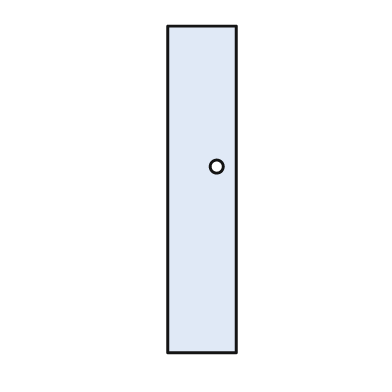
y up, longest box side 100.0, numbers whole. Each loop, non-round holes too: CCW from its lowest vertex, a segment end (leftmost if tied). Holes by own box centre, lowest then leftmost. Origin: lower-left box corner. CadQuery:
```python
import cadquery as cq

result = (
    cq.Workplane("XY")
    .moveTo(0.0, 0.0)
    .lineTo(21.0, 0.0)
    .lineTo(21.0, 100.0)
    .lineTo(0.0, 100.0)
    .close()
    .moveTo(15.0, 57.0)
    .circle(2.0)
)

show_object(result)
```